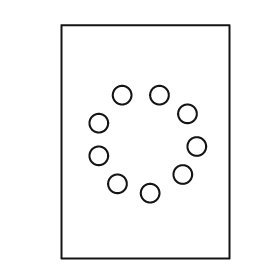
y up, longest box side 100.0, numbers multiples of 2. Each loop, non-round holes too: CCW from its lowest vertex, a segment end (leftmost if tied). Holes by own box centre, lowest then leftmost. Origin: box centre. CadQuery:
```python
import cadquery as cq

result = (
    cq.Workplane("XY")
    .moveTo(-36.0, -50.0)
    .lineTo(36.0, -50.0)
    .lineTo(36.0, 50.0)
    .lineTo(-36.0, 50.0)
    .close()
    .moveTo(2.0, -22.0)
    .circle(4.0)
    .moveTo(-12.0, -18.0)
    .circle(4.0)
    .moveTo(16.0, -14.0)
    .circle(4.0)
    .moveTo(-20.0, -6.0)
    .circle(4.0)
    .moveTo(22.0, -2.0)
    .circle(4.0)
    .moveTo(-20.0, 8.0)
    .circle(4.0)
    .moveTo(18.0, 12.0)
    .circle(4.0)
    .moveTo(-10.0, 20.0)
    .circle(4.0)
    .moveTo(6.0, 20.0)
    .circle(4.0)
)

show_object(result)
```